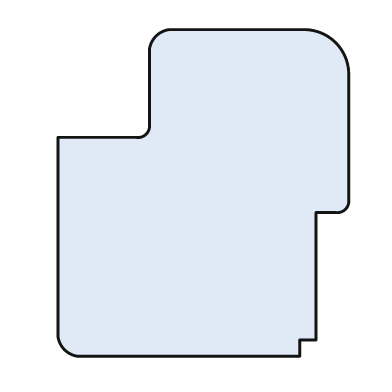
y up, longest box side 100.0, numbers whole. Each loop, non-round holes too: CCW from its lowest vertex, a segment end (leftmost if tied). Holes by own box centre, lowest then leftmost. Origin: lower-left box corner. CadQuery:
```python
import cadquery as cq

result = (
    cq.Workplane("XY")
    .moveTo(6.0, 0.0)
    .lineTo(74.0, 0.0)
    .lineTo(74.0, 5.0)
    .lineTo(79.0, 5.0)
    .lineTo(79.0, 44.0)
    .lineTo(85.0, 44.0)
    .threePointArc((88.0, 45.0), (89.0, 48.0))
    .lineTo(89.0, 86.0)
    .threePointArc((85.0, 96.0), (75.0, 100.0))
    .lineTo(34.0, 100.0)
    .threePointArc((30.0, 98.0), (28.0, 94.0))
    .lineTo(28.0, 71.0)
    .threePointArc((27.0, 68.0), (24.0, 67.0))
    .lineTo(0.0, 67.0)
    .lineTo(0.0, 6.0)
    .threePointArc((2.0, 2.0), (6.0, 0.0))
    .close()
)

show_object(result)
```